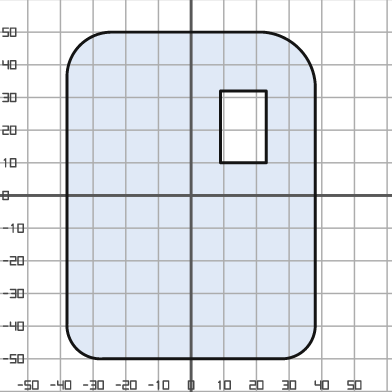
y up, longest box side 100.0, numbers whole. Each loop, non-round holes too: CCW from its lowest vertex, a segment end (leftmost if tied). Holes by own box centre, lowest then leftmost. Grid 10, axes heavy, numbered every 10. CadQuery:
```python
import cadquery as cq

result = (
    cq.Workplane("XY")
    .moveTo(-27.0, -50.0)
    .lineTo(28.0, -50.0)
    .threePointArc((35.0, -47.0), (38.0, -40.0))
    .lineTo(38.0, 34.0)
    .threePointArc((33.0, 45.0), (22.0, 50.0))
    .lineTo(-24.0, 50.0)
    .threePointArc((-34.0, 46.0), (-38.0, 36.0))
    .lineTo(-38.0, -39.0)
    .threePointArc((-35.0, -47.0), (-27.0, -50.0))
    .close()
    .moveTo(9.0, 10.0)
    .lineTo(23.0, 10.0)
    .lineTo(23.0, 32.0)
    .lineTo(9.0, 32.0)
    .close()
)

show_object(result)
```